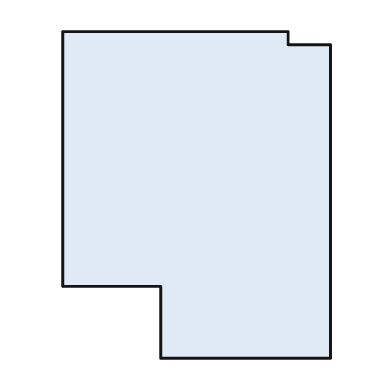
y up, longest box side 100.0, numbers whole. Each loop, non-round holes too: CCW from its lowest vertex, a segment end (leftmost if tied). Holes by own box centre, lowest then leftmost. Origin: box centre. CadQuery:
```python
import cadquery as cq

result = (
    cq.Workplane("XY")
    .moveTo(-11.0, -50.0)
    .lineTo(41.0, -50.0)
    .lineTo(41.0, 46.0)
    .lineTo(28.0, 46.0)
    .lineTo(28.0, 50.0)
    .lineTo(-41.0, 50.0)
    .lineTo(-41.0, -28.0)
    .lineTo(-11.0, -28.0)
    .close()
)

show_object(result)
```